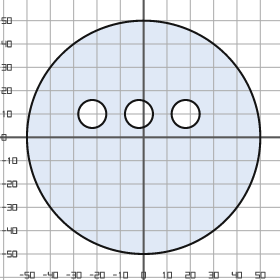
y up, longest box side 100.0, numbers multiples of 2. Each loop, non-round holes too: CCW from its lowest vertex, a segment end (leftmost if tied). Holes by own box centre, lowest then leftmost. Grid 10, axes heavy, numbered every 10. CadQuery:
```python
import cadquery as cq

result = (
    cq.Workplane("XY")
    .moveTo(0.0, 0.0)
    .circle(50.0)
    .moveTo(-22.0, 10.0)
    .circle(6.0)
    .moveTo(-2.0, 10.0)
    .circle(6.0)
    .moveTo(18.0, 10.0)
    .circle(6.0)
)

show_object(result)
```